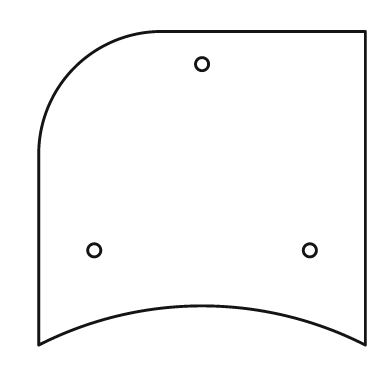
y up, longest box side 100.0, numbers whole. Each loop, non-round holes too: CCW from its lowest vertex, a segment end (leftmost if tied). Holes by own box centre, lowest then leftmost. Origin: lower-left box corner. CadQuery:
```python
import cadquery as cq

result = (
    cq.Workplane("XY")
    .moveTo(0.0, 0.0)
    .threePointArc((50.0, 12.0), (100.0, 0.0))
    .lineTo(100.0, 96.0)
    .lineTo(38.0, 96.0)
    .threePointArc((11.0, 85.0), (0.0, 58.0))
    .close()
    .moveTo(17.0, 29.0)
    .circle(2.0)
    .moveTo(83.0, 29.0)
    .circle(2.0)
    .moveTo(50.0, 86.0)
    .circle(2.0)
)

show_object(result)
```